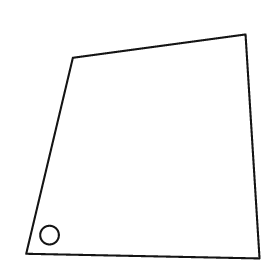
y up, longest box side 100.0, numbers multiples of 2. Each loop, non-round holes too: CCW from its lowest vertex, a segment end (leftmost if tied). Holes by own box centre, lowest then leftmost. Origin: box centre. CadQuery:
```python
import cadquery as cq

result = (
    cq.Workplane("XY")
    .moveTo(50.0, -48.0)
    .lineTo(44.0, 48.0)
    .lineTo(-30.0, 38.0)
    .lineTo(-50.0, -46.0)
    .close()
    .moveTo(-40.0, -38.0)
    .circle(4.0)
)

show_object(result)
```